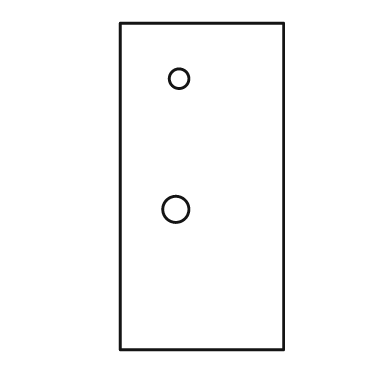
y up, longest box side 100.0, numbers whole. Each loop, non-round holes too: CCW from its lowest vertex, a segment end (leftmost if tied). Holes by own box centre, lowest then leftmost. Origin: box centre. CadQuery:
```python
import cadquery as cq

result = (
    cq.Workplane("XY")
    .moveTo(-25.0, -50.0)
    .lineTo(25.0, -50.0)
    .lineTo(25.0, 50.0)
    .lineTo(-25.0, 50.0)
    .close()
    .moveTo(-8.0, -7.0)
    .circle(4.0)
    .moveTo(-7.0, 33.0)
    .circle(3.0)
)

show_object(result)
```